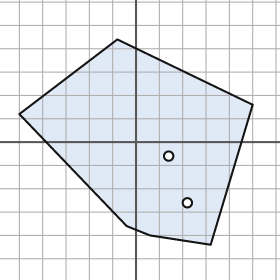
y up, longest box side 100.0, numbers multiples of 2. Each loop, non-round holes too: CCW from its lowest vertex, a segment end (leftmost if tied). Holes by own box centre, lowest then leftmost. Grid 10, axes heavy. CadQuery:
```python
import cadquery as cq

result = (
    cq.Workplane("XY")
    .moveTo(32.0, -44.0)
    .lineTo(50.0, 16.0)
    .lineTo(-8.0, 44.0)
    .lineTo(-50.0, 12.0)
    .lineTo(-4.0, -36.0)
    .lineTo(6.0, -40.0)
    .close()
    .moveTo(22.0, -26.0)
    .circle(2.0)
    .moveTo(14.0, -6.0)
    .circle(2.0)
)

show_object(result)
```